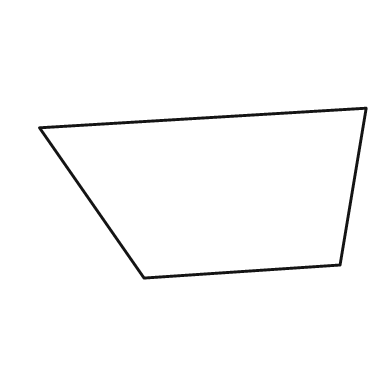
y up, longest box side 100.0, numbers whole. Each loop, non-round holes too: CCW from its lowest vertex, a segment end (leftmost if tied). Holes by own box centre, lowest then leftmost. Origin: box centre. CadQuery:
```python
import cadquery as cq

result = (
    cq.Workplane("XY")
    .moveTo(-18.0, -26.0)
    .lineTo(42.0, -22.0)
    .lineTo(50.0, 26.0)
    .lineTo(-50.0, 20.0)
    .close()
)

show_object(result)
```